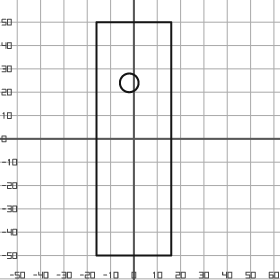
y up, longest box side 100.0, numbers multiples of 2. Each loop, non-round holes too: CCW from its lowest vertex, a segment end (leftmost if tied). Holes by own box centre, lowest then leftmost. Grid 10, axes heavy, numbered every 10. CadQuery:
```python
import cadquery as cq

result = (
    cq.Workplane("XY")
    .moveTo(-16.0, -50.0)
    .lineTo(16.0, -50.0)
    .lineTo(16.0, 50.0)
    .lineTo(-16.0, 50.0)
    .close()
    .moveTo(-2.0, 24.0)
    .circle(4.0)
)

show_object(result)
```